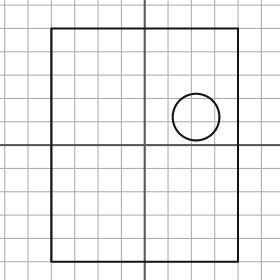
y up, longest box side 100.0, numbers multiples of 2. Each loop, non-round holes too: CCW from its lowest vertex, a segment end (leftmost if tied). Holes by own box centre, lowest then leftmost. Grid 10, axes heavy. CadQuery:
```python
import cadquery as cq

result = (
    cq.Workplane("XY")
    .moveTo(-40.0, -50.0)
    .lineTo(40.0, -50.0)
    .lineTo(40.0, 50.0)
    .lineTo(-40.0, 50.0)
    .close()
    .moveTo(22.0, 12.0)
    .circle(10.0)
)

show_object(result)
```